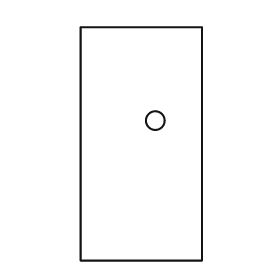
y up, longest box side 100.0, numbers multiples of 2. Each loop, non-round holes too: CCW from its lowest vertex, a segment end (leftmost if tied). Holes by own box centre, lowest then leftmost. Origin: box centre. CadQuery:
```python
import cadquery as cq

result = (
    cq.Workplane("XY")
    .moveTo(-26.0, -50.0)
    .lineTo(26.0, -50.0)
    .lineTo(26.0, 50.0)
    .lineTo(-26.0, 50.0)
    .close()
    .moveTo(6.0, 10.0)
    .circle(4.0)
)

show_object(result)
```